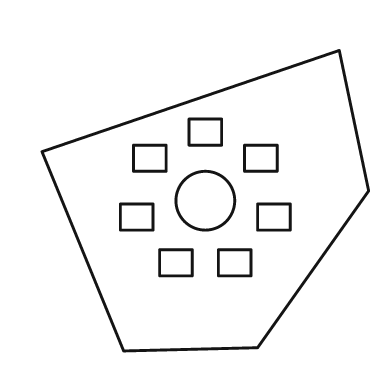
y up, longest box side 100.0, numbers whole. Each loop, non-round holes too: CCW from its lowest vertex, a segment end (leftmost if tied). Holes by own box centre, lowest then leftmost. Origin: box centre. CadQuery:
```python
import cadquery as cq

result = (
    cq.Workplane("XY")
    .moveTo(-25.0, -46.0)
    .lineTo(16.0, -45.0)
    .lineTo(50.0, 3.0)
    .lineTo(41.0, 46.0)
    .lineTo(-50.0, 15.0)
    .close()
    .moveTo(-14.0, -23.0)
    .lineTo(-4.0, -23.0)
    .lineTo(-4.0, -15.0)
    .lineTo(-14.0, -15.0)
    .close()
    .moveTo(4.0, -23.0)
    .lineTo(14.0, -23.0)
    .lineTo(14.0, -15.0)
    .lineTo(4.0, -15.0)
    .close()
    .moveTo(-26.0, -9.0)
    .lineTo(-16.0, -9.0)
    .lineTo(-16.0, -1.0)
    .lineTo(-26.0, -1.0)
    .close()
    .moveTo(16.0, -9.0)
    .lineTo(26.0, -9.0)
    .lineTo(26.0, -1.0)
    .lineTo(16.0, -1.0)
    .close()
    .moveTo(0.0, 0.0)
    .circle(9.0)
    .moveTo(-22.0, 9.0)
    .lineTo(-12.0, 9.0)
    .lineTo(-12.0, 17.0)
    .lineTo(-22.0, 17.0)
    .close()
    .moveTo(12.0, 9.0)
    .lineTo(22.0, 9.0)
    .lineTo(22.0, 17.0)
    .lineTo(12.0, 17.0)
    .close()
    .moveTo(-5.0, 17.0)
    .lineTo(5.0, 17.0)
    .lineTo(5.0, 25.0)
    .lineTo(-5.0, 25.0)
    .close()
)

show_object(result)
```